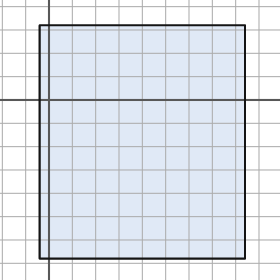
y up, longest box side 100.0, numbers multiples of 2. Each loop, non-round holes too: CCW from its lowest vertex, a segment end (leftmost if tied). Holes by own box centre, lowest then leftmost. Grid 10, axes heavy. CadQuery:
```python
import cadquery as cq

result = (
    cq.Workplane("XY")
    .moveTo(-4.0, -68.0)
    .lineTo(84.0, -68.0)
    .lineTo(84.0, 32.0)
    .lineTo(-4.0, 32.0)
    .close()
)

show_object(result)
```